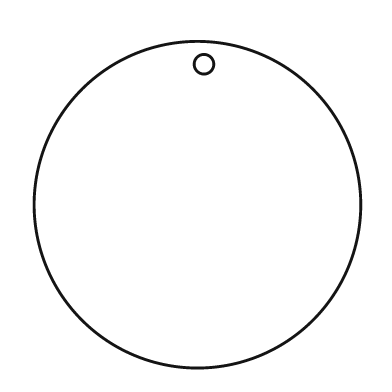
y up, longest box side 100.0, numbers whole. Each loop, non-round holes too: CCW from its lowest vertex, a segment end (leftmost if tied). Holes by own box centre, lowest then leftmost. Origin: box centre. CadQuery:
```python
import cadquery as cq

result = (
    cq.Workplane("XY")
    .moveTo(0.0, 0.0)
    .circle(50.0)
    .moveTo(2.0, 43.0)
    .circle(3.0)
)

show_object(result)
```